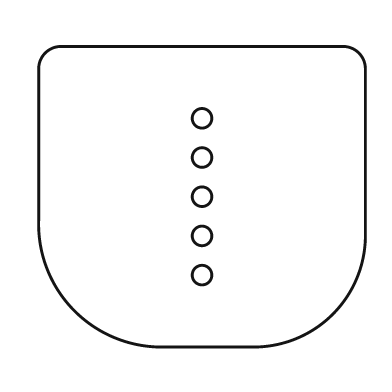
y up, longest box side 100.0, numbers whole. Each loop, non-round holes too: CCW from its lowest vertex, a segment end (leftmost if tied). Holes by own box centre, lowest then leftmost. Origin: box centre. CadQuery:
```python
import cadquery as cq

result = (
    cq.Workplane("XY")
    .moveTo(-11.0, -46.0)
    .lineTo(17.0, -46.0)
    .threePointArc((40.0, -36.0), (50.0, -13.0))
    .lineTo(50.0, 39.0)
    .threePointArc((48.0, 44.0), (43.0, 46.0))
    .lineTo(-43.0, 46.0)
    .threePointArc((-48.0, 44.0), (-50.0, 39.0))
    .lineTo(-50.0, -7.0)
    .threePointArc((-39.0, -35.0), (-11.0, -46.0))
    .close()
    .moveTo(0.0, -24.0)
    .circle(3.0)
    .moveTo(0.0, -12.0)
    .circle(3.0)
    .moveTo(0.0, 0.0)
    .circle(3.0)
    .moveTo(0.0, 12.0)
    .circle(3.0)
    .moveTo(0.0, 24.0)
    .circle(3.0)
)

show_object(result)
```